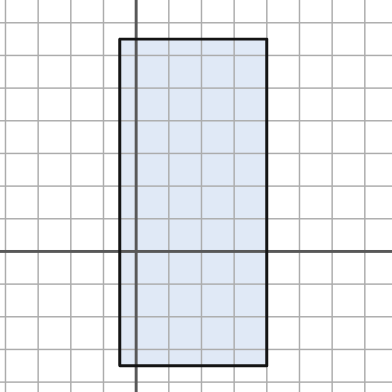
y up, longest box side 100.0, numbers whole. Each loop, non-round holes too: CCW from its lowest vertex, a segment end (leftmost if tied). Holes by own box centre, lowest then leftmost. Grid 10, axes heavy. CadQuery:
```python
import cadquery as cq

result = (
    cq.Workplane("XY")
    .moveTo(-5.0, -35.0)
    .lineTo(40.0, -35.0)
    .lineTo(40.0, 65.0)
    .lineTo(-5.0, 65.0)
    .close()
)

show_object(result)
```